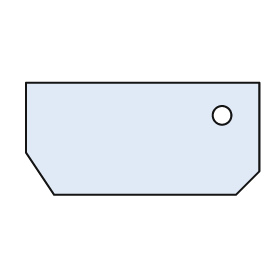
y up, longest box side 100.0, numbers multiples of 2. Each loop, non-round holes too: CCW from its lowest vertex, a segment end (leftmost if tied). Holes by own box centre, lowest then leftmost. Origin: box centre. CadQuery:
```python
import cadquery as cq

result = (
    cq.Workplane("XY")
    .moveTo(-38.0, -24.0)
    .lineTo(40.0, -24.0)
    .lineTo(50.0, -14.0)
    .lineTo(50.0, 24.0)
    .lineTo(-50.0, 24.0)
    .lineTo(-50.0, -6.0)
    .close()
    .moveTo(34.0, 10.0)
    .circle(4.0)
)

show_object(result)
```